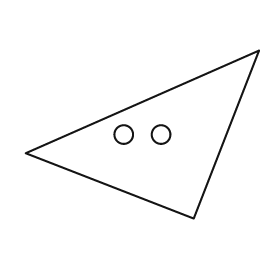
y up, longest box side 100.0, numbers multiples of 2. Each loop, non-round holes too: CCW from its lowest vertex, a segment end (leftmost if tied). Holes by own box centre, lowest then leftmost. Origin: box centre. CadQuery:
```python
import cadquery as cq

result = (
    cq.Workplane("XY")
    .moveTo(22.0, -36.0)
    .lineTo(50.0, 36.0)
    .lineTo(-50.0, -8.0)
    .close()
    .moveTo(-8.0, 0.0)
    .circle(4.0)
    .moveTo(8.0, 0.0)
    .circle(4.0)
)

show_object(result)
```